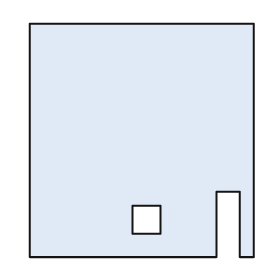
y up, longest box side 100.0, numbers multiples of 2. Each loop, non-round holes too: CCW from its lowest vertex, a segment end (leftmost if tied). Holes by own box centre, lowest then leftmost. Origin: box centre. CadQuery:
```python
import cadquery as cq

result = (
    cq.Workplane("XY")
    .moveTo(-48.0, -50.0)
    .lineTo(32.0, -50.0)
    .lineTo(32.0, -22.0)
    .lineTo(42.0, -22.0)
    .lineTo(42.0, -50.0)
    .lineTo(48.0, -50.0)
    .lineTo(48.0, 50.0)
    .lineTo(-48.0, 50.0)
    .close()
    .moveTo(-4.0, -40.0)
    .lineTo(8.0, -40.0)
    .lineTo(8.0, -28.0)
    .lineTo(-4.0, -28.0)
    .close()
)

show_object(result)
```